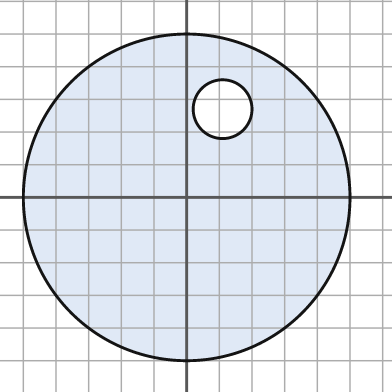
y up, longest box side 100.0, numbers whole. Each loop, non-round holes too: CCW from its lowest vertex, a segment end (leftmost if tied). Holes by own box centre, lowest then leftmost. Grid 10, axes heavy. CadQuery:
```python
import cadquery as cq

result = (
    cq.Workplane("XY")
    .moveTo(0.0, 0.0)
    .circle(50.0)
    .moveTo(11.0, 27.0)
    .circle(9.0)
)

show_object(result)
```